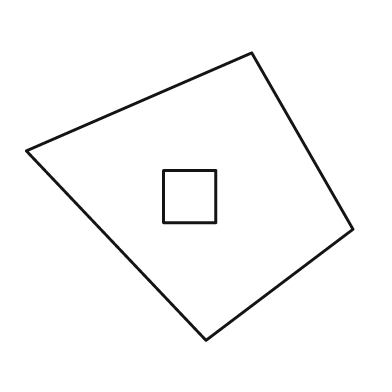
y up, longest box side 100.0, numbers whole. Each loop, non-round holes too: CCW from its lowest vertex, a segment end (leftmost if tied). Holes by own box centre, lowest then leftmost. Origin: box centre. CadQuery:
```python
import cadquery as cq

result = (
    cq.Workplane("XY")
    .moveTo(5.0, -44.0)
    .lineTo(50.0, -10.0)
    .lineTo(19.0, 44.0)
    .lineTo(-50.0, 14.0)
    .close()
    .moveTo(-8.0, -8.0)
    .lineTo(8.0, -8.0)
    .lineTo(8.0, 8.0)
    .lineTo(-8.0, 8.0)
    .close()
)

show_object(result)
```